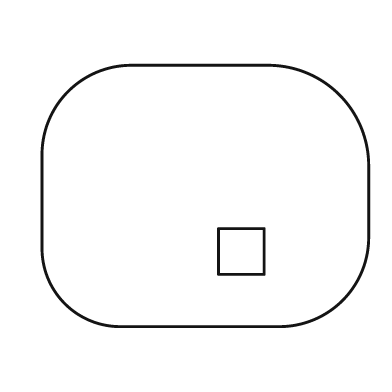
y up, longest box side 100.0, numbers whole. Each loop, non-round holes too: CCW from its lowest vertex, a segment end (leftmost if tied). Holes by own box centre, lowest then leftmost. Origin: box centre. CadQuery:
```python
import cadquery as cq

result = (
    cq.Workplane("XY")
    .moveTo(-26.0, -40.0)
    .lineTo(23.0, -40.0)
    .threePointArc((42.0, -32.0), (50.0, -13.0))
    .lineTo(50.0, 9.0)
    .threePointArc((41.0, 31.0), (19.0, 40.0))
    .lineTo(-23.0, 40.0)
    .threePointArc((-42.0, 32.0), (-50.0, 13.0))
    .lineTo(-50.0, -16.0)
    .threePointArc((-43.0, -33.0), (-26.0, -40.0))
    .close()
    .moveTo(4.0, -24.0)
    .lineTo(18.0, -24.0)
    .lineTo(18.0, -10.0)
    .lineTo(4.0, -10.0)
    .close()
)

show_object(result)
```